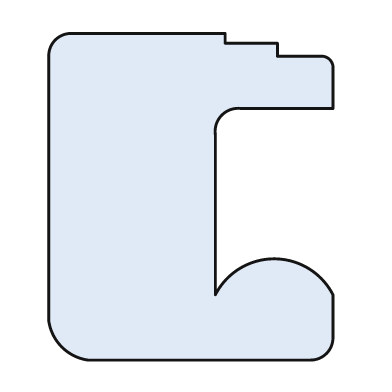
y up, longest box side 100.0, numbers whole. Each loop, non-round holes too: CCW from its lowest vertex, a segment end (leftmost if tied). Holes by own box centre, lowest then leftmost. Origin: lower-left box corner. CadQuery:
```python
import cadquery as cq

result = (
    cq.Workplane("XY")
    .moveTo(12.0, 0.0)
    .lineTo(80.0, 0.0)
    .threePointArc((85.0, 2.0), (87.0, 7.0))
    .lineTo(87.0, 20.0)
    .threePointArc((69.0, 31.0), (51.0, 20.0))
    .lineTo(51.0, 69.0)
    .threePointArc((53.0, 75.0), (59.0, 77.0))
    .lineTo(87.0, 77.0)
    .lineTo(87.0, 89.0)
    .threePointArc((86.0, 92.0), (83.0, 93.0))
    .lineTo(70.0, 93.0)
    .lineTo(70.0, 97.0)
    .lineTo(54.0, 97.0)
    .lineTo(54.0, 100.0)
    .lineTo(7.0, 100.0)
    .threePointArc((2.0, 98.0), (0.0, 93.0))
    .lineTo(0.0, 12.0)
    .threePointArc((4.0, 4.0), (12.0, 0.0))
    .close()
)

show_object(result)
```